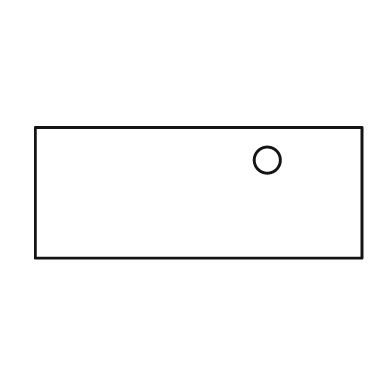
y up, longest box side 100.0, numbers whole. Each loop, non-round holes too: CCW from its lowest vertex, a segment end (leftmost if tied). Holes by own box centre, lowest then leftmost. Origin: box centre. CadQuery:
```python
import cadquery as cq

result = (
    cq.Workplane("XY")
    .moveTo(-50.0, -20.0)
    .lineTo(50.0, -20.0)
    .lineTo(50.0, 20.0)
    .lineTo(-50.0, 20.0)
    .close()
    .moveTo(21.0, 10.0)
    .circle(4.0)
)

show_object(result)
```